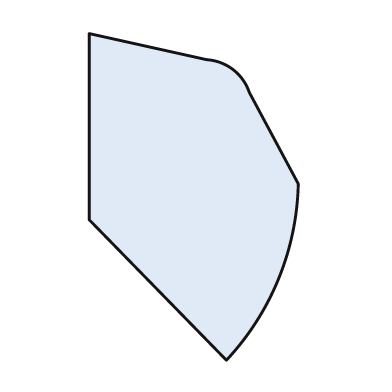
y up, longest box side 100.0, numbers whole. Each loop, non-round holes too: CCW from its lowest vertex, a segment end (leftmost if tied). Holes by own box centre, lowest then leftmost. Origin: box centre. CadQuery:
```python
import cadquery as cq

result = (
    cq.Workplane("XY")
    .moveTo(10.0, -50.0)
    .threePointArc((26.0, -25.0), (32.0, 4.0))
    .lineTo(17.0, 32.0)
    .threePointArc((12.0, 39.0), (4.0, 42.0))
    .lineTo(-32.0, 50.0)
    .lineTo(-32.0, -7.0)
    .close()
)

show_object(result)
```